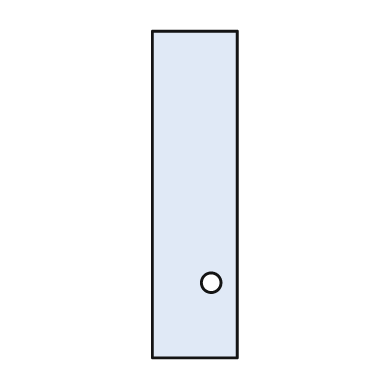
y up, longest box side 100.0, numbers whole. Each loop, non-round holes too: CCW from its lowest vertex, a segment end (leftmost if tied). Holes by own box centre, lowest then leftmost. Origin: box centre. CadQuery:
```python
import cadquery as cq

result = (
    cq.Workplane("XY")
    .moveTo(-13.0, -50.0)
    .lineTo(13.0, -50.0)
    .lineTo(13.0, 50.0)
    .lineTo(-13.0, 50.0)
    .close()
    .moveTo(5.0, -27.0)
    .circle(3.0)
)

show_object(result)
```